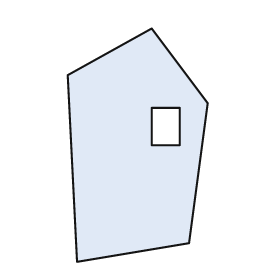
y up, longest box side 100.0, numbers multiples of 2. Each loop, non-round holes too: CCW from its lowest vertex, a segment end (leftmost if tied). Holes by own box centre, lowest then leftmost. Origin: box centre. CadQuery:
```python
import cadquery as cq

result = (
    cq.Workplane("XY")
    .moveTo(-26.0, -50.0)
    .lineTo(22.0, -42.0)
    .lineTo(30.0, 18.0)
    .lineTo(6.0, 50.0)
    .lineTo(-30.0, 30.0)
    .close()
    .moveTo(6.0, 0.0)
    .lineTo(18.0, 0.0)
    .lineTo(18.0, 16.0)
    .lineTo(6.0, 16.0)
    .close()
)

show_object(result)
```